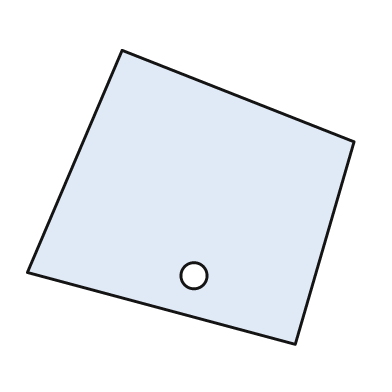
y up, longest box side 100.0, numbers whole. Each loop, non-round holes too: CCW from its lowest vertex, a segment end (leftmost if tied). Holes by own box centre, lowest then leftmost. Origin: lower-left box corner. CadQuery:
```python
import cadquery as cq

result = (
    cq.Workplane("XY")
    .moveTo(82.0, 0.0)
    .lineTo(100.0, 62.0)
    .lineTo(29.0, 90.0)
    .lineTo(0.0, 22.0)
    .close()
    .moveTo(51.0, 21.0)
    .circle(4.0)
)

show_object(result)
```